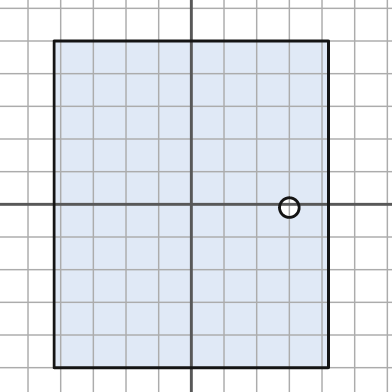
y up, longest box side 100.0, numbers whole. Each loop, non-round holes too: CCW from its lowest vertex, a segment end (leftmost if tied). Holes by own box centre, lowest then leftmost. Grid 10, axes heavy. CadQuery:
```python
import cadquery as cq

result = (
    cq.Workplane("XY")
    .moveTo(-42.0, -50.0)
    .lineTo(42.0, -50.0)
    .lineTo(42.0, 50.0)
    .lineTo(-42.0, 50.0)
    .close()
    .moveTo(30.0, -1.0)
    .circle(3.0)
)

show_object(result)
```